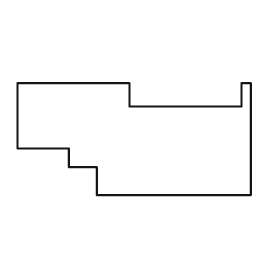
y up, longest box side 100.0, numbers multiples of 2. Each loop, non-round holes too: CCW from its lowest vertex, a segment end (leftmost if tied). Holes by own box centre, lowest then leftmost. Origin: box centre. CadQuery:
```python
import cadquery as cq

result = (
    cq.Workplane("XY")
    .moveTo(-16.0, -24.0)
    .lineTo(50.0, -24.0)
    .lineTo(50.0, 24.0)
    .lineTo(46.0, 24.0)
    .lineTo(46.0, 14.0)
    .lineTo(-2.0, 14.0)
    .lineTo(-2.0, 24.0)
    .lineTo(-50.0, 24.0)
    .lineTo(-50.0, -4.0)
    .lineTo(-28.0, -4.0)
    .lineTo(-28.0, -12.0)
    .lineTo(-16.0, -12.0)
    .close()
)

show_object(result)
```